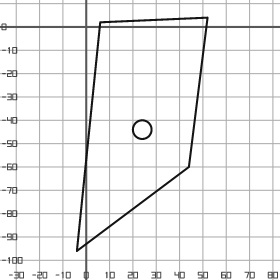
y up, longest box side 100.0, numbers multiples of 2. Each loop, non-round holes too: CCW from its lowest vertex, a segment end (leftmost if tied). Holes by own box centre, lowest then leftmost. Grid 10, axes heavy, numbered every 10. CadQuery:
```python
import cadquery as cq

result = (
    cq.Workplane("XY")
    .moveTo(-4.0, -96.0)
    .lineTo(44.0, -60.0)
    .lineTo(52.0, 4.0)
    .lineTo(6.0, 2.0)
    .close()
    .moveTo(24.0, -44.0)
    .circle(4.0)
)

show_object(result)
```